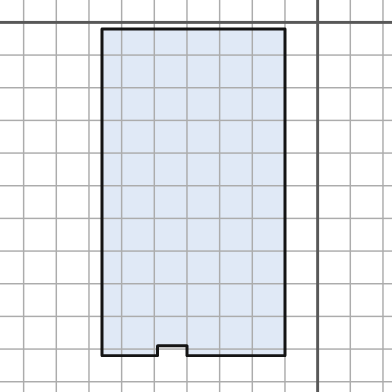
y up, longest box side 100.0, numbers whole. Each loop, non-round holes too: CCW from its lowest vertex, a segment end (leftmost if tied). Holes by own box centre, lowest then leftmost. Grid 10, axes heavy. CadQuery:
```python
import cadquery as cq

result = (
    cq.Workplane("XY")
    .moveTo(-66.0, -102.0)
    .lineTo(-49.0, -102.0)
    .lineTo(-49.0, -99.0)
    .lineTo(-40.0, -99.0)
    .lineTo(-40.0, -102.0)
    .lineTo(-10.0, -102.0)
    .lineTo(-10.0, -2.0)
    .lineTo(-66.0, -2.0)
    .close()
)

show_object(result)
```